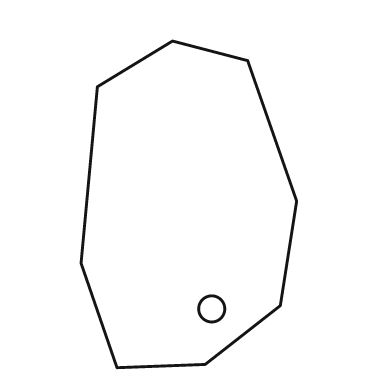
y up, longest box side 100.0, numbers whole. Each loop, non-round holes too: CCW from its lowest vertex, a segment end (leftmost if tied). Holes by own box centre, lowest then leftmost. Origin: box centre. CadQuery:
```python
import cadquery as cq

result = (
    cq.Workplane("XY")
    .moveTo(-22.0, -50.0)
    .lineTo(5.0, -49.0)
    .lineTo(28.0, -31.0)
    .lineTo(33.0, 1.0)
    .lineTo(18.0, 44.0)
    .lineTo(-5.0, 50.0)
    .lineTo(-28.0, 36.0)
    .lineTo(-33.0, -18.0)
    .close()
    .moveTo(7.0, -32.0)
    .circle(4.0)
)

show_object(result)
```